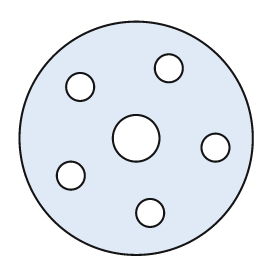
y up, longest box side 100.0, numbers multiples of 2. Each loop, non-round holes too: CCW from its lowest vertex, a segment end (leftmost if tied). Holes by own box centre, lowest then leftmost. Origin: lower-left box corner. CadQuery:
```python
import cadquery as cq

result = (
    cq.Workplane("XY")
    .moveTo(50.0, 50.0)
    .circle(50.0)
    .moveTo(56.0, 18.0)
    .circle(6.0)
    .moveTo(22.0, 34.0)
    .circle(6.0)
    .moveTo(84.0, 46.0)
    .circle(6.0)
    .moveTo(50.0, 50.0)
    .circle(10.0)
    .moveTo(26.0, 72.0)
    .circle(6.0)
    .moveTo(64.0, 80.0)
    .circle(6.0)
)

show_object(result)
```